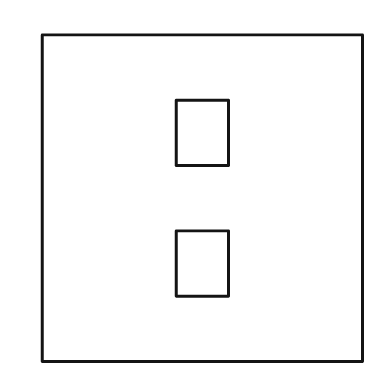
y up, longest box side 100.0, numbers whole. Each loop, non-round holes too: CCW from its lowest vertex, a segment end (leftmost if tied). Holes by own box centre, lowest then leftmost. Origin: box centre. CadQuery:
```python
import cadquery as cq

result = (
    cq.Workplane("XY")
    .moveTo(-49.0, -50.0)
    .lineTo(49.0, -50.0)
    .lineTo(49.0, 50.0)
    .lineTo(-49.0, 50.0)
    .close()
    .moveTo(-8.0, -30.0)
    .lineTo(8.0, -30.0)
    .lineTo(8.0, -10.0)
    .lineTo(-8.0, -10.0)
    .close()
    .moveTo(-8.0, 10.0)
    .lineTo(8.0, 10.0)
    .lineTo(8.0, 30.0)
    .lineTo(-8.0, 30.0)
    .close()
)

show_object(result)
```